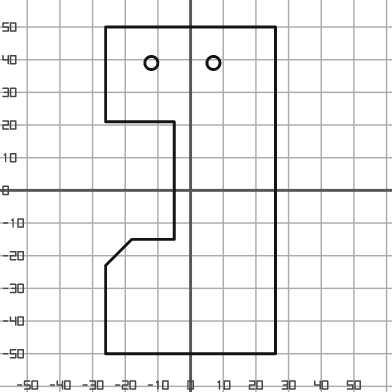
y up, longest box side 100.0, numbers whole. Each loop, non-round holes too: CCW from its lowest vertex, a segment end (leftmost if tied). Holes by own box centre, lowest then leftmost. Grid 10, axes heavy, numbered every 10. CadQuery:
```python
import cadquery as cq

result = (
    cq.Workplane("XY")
    .moveTo(-26.0, -50.0)
    .lineTo(26.0, -50.0)
    .lineTo(26.0, 50.0)
    .lineTo(-26.0, 50.0)
    .lineTo(-26.0, 21.0)
    .lineTo(-5.0, 21.0)
    .lineTo(-5.0, -15.0)
    .lineTo(-18.0, -15.0)
    .lineTo(-26.0, -23.0)
    .close()
    .moveTo(-12.0, 39.0)
    .circle(2.0)
    .moveTo(7.0, 39.0)
    .circle(2.0)
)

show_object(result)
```